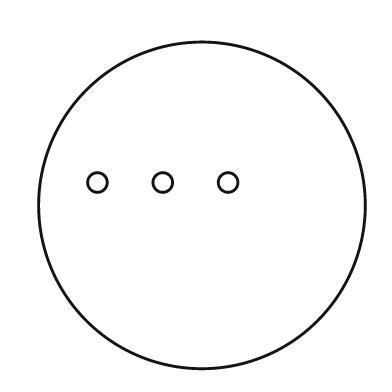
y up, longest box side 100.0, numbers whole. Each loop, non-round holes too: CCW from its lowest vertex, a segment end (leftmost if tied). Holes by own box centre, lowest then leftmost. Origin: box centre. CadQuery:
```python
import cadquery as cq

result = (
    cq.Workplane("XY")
    .moveTo(0.0, 0.0)
    .circle(50.0)
    .moveTo(-32.0, 7.0)
    .circle(3.0)
    .moveTo(-12.0, 7.0)
    .circle(3.0)
    .moveTo(8.0, 7.0)
    .circle(3.0)
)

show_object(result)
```